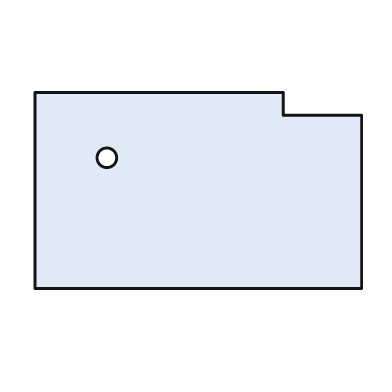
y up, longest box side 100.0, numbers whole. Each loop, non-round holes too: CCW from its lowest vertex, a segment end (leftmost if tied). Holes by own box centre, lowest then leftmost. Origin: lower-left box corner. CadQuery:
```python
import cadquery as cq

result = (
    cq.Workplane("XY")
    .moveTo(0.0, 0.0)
    .lineTo(100.0, 0.0)
    .lineTo(100.0, 53.0)
    .lineTo(76.0, 53.0)
    .lineTo(76.0, 60.0)
    .lineTo(0.0, 60.0)
    .close()
    .moveTo(22.0, 40.0)
    .circle(3.0)
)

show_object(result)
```